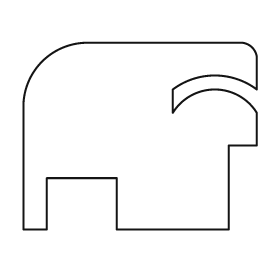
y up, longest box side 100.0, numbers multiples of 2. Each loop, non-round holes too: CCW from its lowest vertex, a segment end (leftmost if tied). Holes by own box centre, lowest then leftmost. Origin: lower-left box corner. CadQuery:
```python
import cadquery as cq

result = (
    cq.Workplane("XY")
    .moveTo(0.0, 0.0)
    .lineTo(10.0, 0.0)
    .lineTo(10.0, 22.0)
    .lineTo(40.0, 22.0)
    .lineTo(40.0, 0.0)
    .lineTo(88.0, 0.0)
    .lineTo(88.0, 36.0)
    .lineTo(100.0, 36.0)
    .lineTo(100.0, 50.0)
    .threePointArc((82.0, 60.0), (64.0, 50.0))
    .lineTo(64.0, 60.0)
    .threePointArc((82.0, 66.0), (100.0, 60.0))
    .lineTo(100.0, 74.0)
    .threePointArc((98.0, 78.0), (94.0, 80.0))
    .lineTo(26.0, 80.0)
    .threePointArc((8.0, 72.0), (0.0, 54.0))
    .close()
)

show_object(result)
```